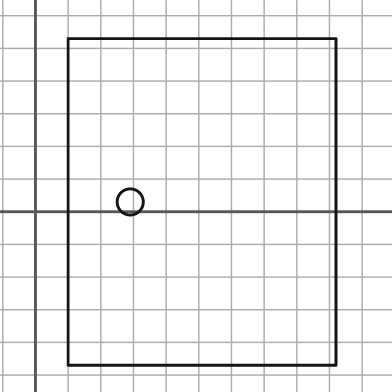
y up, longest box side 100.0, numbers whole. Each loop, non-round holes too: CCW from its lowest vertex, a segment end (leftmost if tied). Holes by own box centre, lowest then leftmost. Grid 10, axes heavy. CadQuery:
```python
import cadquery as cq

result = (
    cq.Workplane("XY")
    .moveTo(10.0, -47.0)
    .lineTo(92.0, -47.0)
    .lineTo(92.0, 53.0)
    .lineTo(10.0, 53.0)
    .close()
    .moveTo(29.0, 3.0)
    .circle(4.0)
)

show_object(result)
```